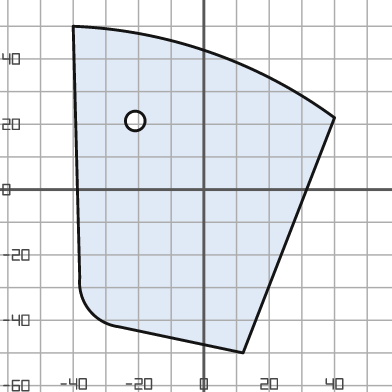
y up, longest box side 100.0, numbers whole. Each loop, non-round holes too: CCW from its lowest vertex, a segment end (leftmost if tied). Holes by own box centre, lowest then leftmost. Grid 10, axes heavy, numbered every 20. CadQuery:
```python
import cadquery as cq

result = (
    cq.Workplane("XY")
    .moveTo(12.0, -50.0)
    .lineTo(40.0, 22.0)
    .threePointArc((2.0, 42.0), (-40.0, 50.0))
    .lineTo(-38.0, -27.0)
    .threePointArc((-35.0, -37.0), (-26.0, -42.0))
    .close()
    .moveTo(-21.0, 21.0)
    .circle(3.0)
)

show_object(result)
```